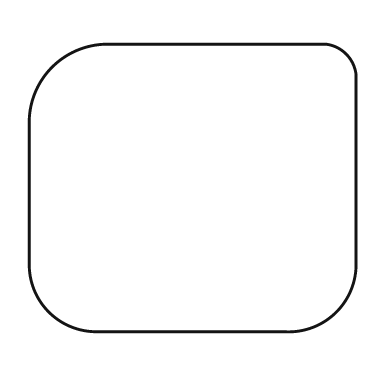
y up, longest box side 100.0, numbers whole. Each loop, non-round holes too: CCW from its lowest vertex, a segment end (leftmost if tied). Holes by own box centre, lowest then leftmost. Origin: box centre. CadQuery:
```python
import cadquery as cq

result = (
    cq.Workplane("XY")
    .moveTo(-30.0, -44.0)
    .lineTo(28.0, -44.0)
    .threePointArc((44.0, -38.0), (50.0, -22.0))
    .lineTo(50.0, 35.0)
    .threePointArc((47.0, 41.0), (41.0, 44.0))
    .lineTo(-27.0, 44.0)
    .threePointArc((-43.0, 37.0), (-50.0, 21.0))
    .lineTo(-50.0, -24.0)
    .threePointArc((-44.0, -38.0), (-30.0, -44.0))
    .close()
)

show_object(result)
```